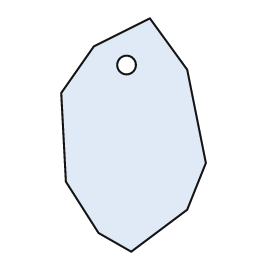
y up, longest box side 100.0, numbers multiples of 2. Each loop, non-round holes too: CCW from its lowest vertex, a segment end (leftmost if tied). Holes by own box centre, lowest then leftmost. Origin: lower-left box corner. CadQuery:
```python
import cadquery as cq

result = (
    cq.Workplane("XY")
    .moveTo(30.0, 0.0)
    .lineTo(54.0, 18.0)
    .lineTo(62.0, 38.0)
    .lineTo(54.0, 78.0)
    .lineTo(38.0, 100.0)
    .lineTo(14.0, 88.0)
    .lineTo(0.0, 68.0)
    .lineTo(2.0, 30.0)
    .lineTo(16.0, 8.0)
    .close()
    .moveTo(28.0, 80.0)
    .circle(4.0)
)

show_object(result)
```